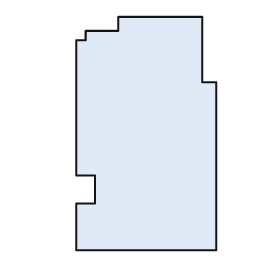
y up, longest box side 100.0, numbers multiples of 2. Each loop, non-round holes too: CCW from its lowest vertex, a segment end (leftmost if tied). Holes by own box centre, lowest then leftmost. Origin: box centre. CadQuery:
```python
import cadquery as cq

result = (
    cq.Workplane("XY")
    .moveTo(-30.0, -50.0)
    .lineTo(30.0, -50.0)
    .lineTo(30.0, 22.0)
    .lineTo(24.0, 22.0)
    .lineTo(24.0, 50.0)
    .lineTo(-12.0, 50.0)
    .lineTo(-12.0, 44.0)
    .lineTo(-26.0, 44.0)
    .lineTo(-26.0, 40.0)
    .lineTo(-30.0, 40.0)
    .lineTo(-30.0, -18.0)
    .lineTo(-22.0, -18.0)
    .lineTo(-22.0, -30.0)
    .lineTo(-30.0, -30.0)
    .close()
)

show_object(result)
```